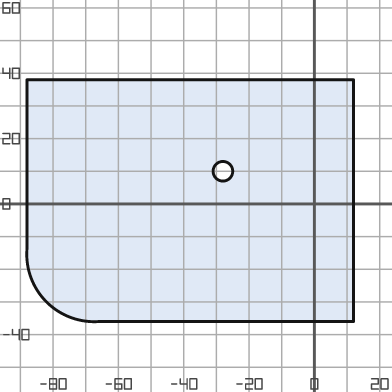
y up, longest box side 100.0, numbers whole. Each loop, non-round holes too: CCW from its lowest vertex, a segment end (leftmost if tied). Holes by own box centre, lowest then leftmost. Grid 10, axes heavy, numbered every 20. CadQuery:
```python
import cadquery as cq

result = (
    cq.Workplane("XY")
    .moveTo(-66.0, -36.0)
    .lineTo(12.0, -36.0)
    .lineTo(12.0, 38.0)
    .lineTo(-88.0, 38.0)
    .lineTo(-88.0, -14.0)
    .threePointArc((-82.0, -30.0), (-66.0, -36.0))
    .close()
    .moveTo(-28.0, 10.0)
    .circle(3.0)
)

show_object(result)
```